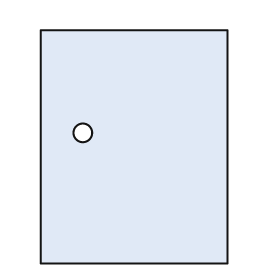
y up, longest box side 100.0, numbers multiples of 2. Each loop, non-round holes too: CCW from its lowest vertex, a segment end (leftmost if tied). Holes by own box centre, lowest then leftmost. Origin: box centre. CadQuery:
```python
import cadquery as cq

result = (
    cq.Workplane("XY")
    .moveTo(-40.0, -50.0)
    .lineTo(40.0, -50.0)
    .lineTo(40.0, 50.0)
    .lineTo(-40.0, 50.0)
    .close()
    .moveTo(-22.0, 6.0)
    .circle(4.0)
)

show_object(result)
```